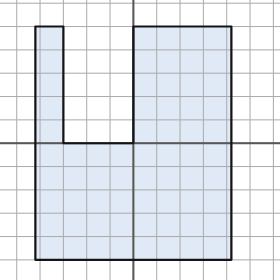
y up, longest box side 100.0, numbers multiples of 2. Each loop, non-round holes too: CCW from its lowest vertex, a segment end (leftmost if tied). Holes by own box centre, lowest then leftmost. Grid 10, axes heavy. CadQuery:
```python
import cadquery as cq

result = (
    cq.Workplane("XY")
    .moveTo(-42.0, -50.0)
    .lineTo(42.0, -50.0)
    .lineTo(42.0, 50.0)
    .lineTo(0.0, 50.0)
    .lineTo(0.0, 0.0)
    .lineTo(-30.0, 0.0)
    .lineTo(-30.0, 50.0)
    .lineTo(-42.0, 50.0)
    .close()
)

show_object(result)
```